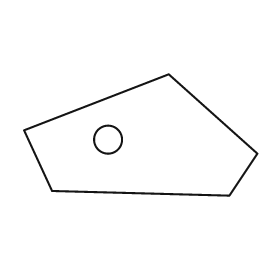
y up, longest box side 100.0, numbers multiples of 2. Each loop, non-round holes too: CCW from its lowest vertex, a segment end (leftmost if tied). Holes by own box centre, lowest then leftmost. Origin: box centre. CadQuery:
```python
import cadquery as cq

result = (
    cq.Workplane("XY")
    .moveTo(38.0, -26.0)
    .lineTo(50.0, -8.0)
    .lineTo(12.0, 26.0)
    .lineTo(-50.0, 2.0)
    .lineTo(-38.0, -24.0)
    .close()
    .moveTo(-14.0, -2.0)
    .circle(6.0)
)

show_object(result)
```